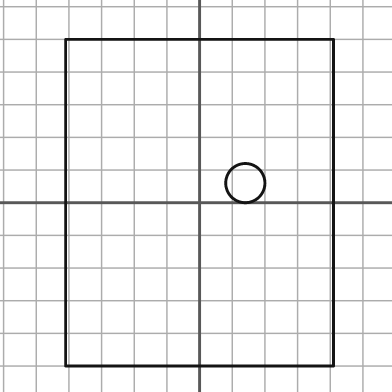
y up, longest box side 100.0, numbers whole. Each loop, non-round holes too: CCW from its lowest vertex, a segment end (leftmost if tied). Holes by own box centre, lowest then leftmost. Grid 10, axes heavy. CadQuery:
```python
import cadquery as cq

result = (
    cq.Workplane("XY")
    .moveTo(-41.0, -50.0)
    .lineTo(41.0, -50.0)
    .lineTo(41.0, 50.0)
    .lineTo(-41.0, 50.0)
    .close()
    .moveTo(14.0, 6.0)
    .circle(6.0)
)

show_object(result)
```